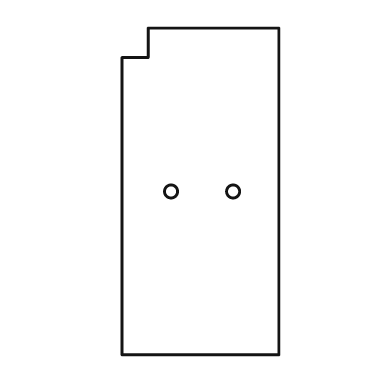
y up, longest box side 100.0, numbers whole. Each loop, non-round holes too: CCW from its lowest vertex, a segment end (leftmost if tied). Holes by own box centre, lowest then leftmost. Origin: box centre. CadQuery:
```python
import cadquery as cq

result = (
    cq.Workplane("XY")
    .moveTo(-24.0, -50.0)
    .lineTo(24.0, -50.0)
    .lineTo(24.0, 50.0)
    .lineTo(-16.0, 50.0)
    .lineTo(-16.0, 41.0)
    .lineTo(-24.0, 41.0)
    .close()
    .moveTo(-9.0, 0.0)
    .circle(2.0)
    .moveTo(10.0, 0.0)
    .circle(2.0)
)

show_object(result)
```